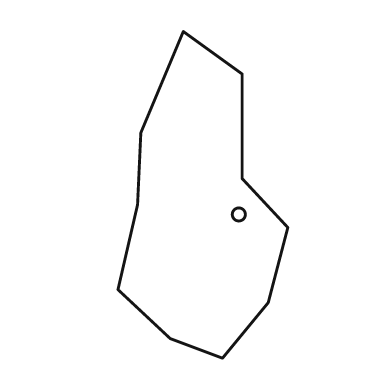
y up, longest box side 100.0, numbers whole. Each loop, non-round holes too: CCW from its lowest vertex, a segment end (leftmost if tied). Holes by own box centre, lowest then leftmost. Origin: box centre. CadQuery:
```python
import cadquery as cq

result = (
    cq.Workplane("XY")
    .moveTo(6.0, -50.0)
    .lineTo(20.0, -33.0)
    .lineTo(26.0, -10.0)
    .lineTo(12.0, 5.0)
    .lineTo(12.0, 37.0)
    .lineTo(-6.0, 50.0)
    .lineTo(-19.0, 19.0)
    .lineTo(-20.0, -3.0)
    .lineTo(-26.0, -29.0)
    .lineTo(-10.0, -44.0)
    .close()
    .moveTo(11.0, -6.0)
    .circle(2.0)
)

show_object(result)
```